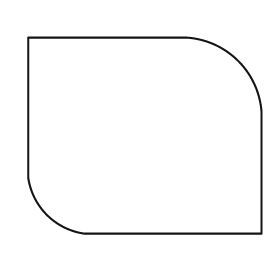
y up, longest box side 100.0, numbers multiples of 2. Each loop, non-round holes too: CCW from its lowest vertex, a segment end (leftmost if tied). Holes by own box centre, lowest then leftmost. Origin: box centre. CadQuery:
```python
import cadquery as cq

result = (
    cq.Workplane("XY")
    .moveTo(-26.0, -42.0)
    .lineTo(50.0, -42.0)
    .lineTo(50.0, 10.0)
    .threePointArc((40.0, 32.0), (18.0, 42.0))
    .lineTo(-50.0, 42.0)
    .lineTo(-50.0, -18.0)
    .threePointArc((-42.0, -34.0), (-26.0, -42.0))
    .close()
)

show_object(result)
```